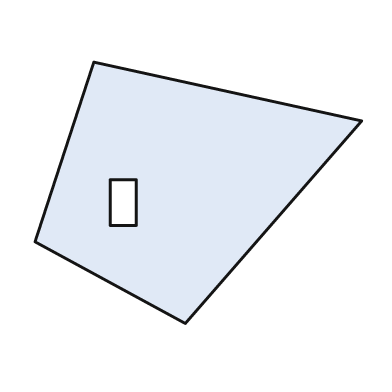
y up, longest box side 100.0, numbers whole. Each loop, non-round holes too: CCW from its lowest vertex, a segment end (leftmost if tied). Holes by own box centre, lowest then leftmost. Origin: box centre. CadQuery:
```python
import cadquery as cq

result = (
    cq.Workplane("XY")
    .moveTo(-4.0, -40.0)
    .lineTo(50.0, 22.0)
    .lineTo(-32.0, 40.0)
    .lineTo(-50.0, -15.0)
    .close()
    .moveTo(-27.0, -10.0)
    .lineTo(-19.0, -10.0)
    .lineTo(-19.0, 4.0)
    .lineTo(-27.0, 4.0)
    .close()
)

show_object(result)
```